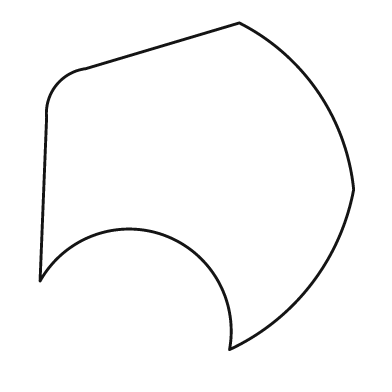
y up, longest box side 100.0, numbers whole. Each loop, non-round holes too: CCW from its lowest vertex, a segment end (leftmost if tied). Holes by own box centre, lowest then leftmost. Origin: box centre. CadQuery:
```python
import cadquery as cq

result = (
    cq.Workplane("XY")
    .moveTo(10.0, -50.0)
    .threePointArc((35.0, -30.0), (48.0, -1.0))
    .threePointArc((37.0, 29.0), (13.0, 50.0))
    .lineTo(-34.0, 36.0)
    .threePointArc((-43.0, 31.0), (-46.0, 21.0))
    .lineTo(-48.0, -29.0)
    .threePointArc((-10.0, -15.0), (10.0, -50.0))
    .close()
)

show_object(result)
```